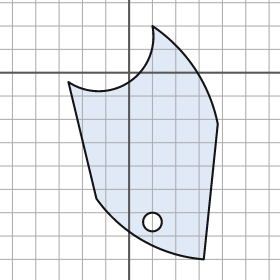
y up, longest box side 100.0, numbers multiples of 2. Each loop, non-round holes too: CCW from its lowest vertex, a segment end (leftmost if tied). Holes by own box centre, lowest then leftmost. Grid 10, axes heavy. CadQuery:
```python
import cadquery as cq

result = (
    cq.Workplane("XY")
    .moveTo(32.0, -80.0)
    .lineTo(38.0, -22.0)
    .threePointArc((28.0, 2.0), (10.0, 20.0))
    .threePointArc((0.0, -4.0), (-26.0, -4.0))
    .lineTo(-14.0, -54.0)
    .threePointArc((6.0, -72.0), (32.0, -80.0))
    .close()
    .moveTo(10.0, -64.0)
    .circle(4.0)
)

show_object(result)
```